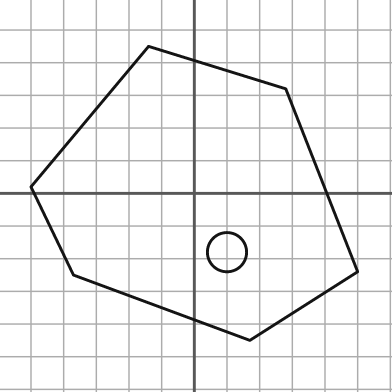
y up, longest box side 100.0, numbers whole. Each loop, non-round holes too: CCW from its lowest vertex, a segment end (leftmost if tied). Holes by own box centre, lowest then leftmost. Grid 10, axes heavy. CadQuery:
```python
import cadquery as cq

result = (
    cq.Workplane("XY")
    .moveTo(17.0, -45.0)
    .lineTo(50.0, -24.0)
    .lineTo(28.0, 32.0)
    .lineTo(-14.0, 45.0)
    .lineTo(-50.0, 2.0)
    .lineTo(-37.0, -25.0)
    .close()
    .moveTo(10.0, -18.0)
    .circle(6.0)
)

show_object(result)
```